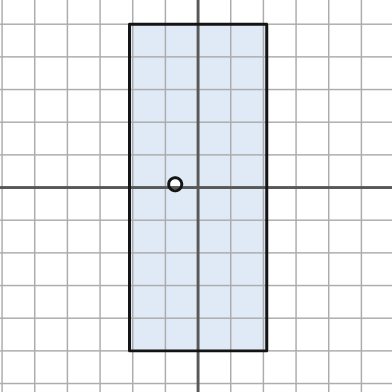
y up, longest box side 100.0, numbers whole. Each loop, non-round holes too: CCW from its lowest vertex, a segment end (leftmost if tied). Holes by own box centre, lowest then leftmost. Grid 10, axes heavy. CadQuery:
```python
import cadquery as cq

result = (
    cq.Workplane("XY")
    .moveTo(-21.0, -50.0)
    .lineTo(21.0, -50.0)
    .lineTo(21.0, 50.0)
    .lineTo(-21.0, 50.0)
    .close()
    .moveTo(-7.0, 1.0)
    .circle(2.0)
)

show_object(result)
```